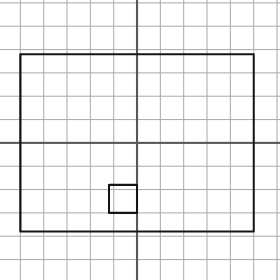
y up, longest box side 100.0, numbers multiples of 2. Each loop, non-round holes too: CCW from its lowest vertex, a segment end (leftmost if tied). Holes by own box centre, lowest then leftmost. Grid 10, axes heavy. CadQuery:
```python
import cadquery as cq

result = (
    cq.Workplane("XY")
    .moveTo(-50.0, -38.0)
    .lineTo(50.0, -38.0)
    .lineTo(50.0, 38.0)
    .lineTo(-50.0, 38.0)
    .close()
    .moveTo(-12.0, -30.0)
    .lineTo(0.0, -30.0)
    .lineTo(0.0, -18.0)
    .lineTo(-12.0, -18.0)
    .close()
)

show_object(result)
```